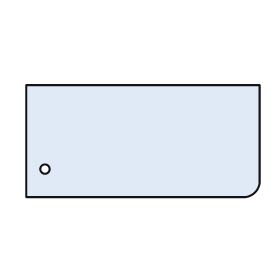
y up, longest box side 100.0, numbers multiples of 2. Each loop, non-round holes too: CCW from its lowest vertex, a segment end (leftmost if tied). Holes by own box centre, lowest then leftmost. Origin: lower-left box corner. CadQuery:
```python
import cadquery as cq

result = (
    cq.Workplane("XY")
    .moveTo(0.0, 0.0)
    .lineTo(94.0, 0.0)
    .threePointArc((98.0, 2.0), (100.0, 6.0))
    .lineTo(100.0, 48.0)
    .lineTo(0.0, 48.0)
    .close()
    .moveTo(8.0, 12.0)
    .circle(2.0)
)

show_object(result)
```